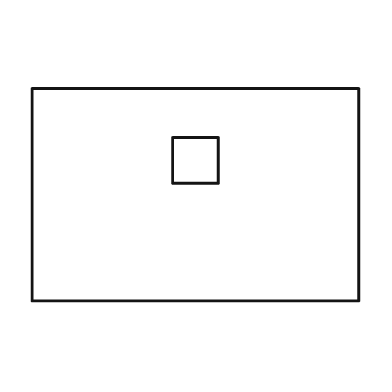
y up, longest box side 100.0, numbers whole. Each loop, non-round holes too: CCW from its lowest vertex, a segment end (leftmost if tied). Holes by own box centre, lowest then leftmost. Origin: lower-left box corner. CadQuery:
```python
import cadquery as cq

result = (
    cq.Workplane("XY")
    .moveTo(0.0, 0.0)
    .lineTo(100.0, 0.0)
    .lineTo(100.0, 65.0)
    .lineTo(0.0, 65.0)
    .close()
    .moveTo(43.0, 36.0)
    .lineTo(57.0, 36.0)
    .lineTo(57.0, 50.0)
    .lineTo(43.0, 50.0)
    .close()
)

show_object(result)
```